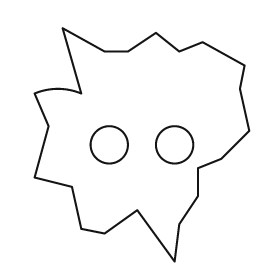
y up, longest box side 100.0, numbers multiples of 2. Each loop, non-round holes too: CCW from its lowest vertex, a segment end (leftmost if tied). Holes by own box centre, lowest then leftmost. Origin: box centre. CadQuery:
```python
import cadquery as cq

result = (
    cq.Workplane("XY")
    .moveTo(14.0, -50.0)
    .lineTo(16.0, -34.0)
    .lineTo(24.0, -22.0)
    .lineTo(24.0, -10.0)
    .lineTo(34.0, -6.0)
    .lineTo(46.0, 6.0)
    .lineTo(42.0, 24.0)
    .lineTo(44.0, 34.0)
    .lineTo(26.0, 44.0)
    .lineTo(16.0, 40.0)
    .lineTo(6.0, 48.0)
    .lineTo(-6.0, 40.0)
    .lineTo(-16.0, 40.0)
    .lineTo(-34.0, 50.0)
    .lineTo(-26.0, 22.0)
    .threePointArc((-36.0, 24.0), (-46.0, 22.0))
    .lineTo(-40.0, 8.0)
    .lineTo(-46.0, -14.0)
    .lineTo(-30.0, -18.0)
    .lineTo(-26.0, -36.0)
    .lineTo(-16.0, -38.0)
    .lineTo(-2.0, -28.0)
    .close()
    .moveTo(-14.0, 0.0)
    .circle(8.0)
    .moveTo(14.0, 0.0)
    .circle(8.0)
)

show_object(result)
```